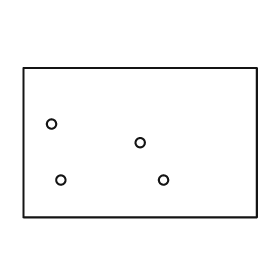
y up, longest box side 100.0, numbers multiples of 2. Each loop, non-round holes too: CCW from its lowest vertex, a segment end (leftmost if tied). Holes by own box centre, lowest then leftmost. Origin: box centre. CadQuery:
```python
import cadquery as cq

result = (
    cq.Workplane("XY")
    .moveTo(-50.0, -32.0)
    .lineTo(50.0, -32.0)
    .lineTo(50.0, 32.0)
    .lineTo(-50.0, 32.0)
    .close()
    .moveTo(-34.0, -16.0)
    .circle(2.0)
    .moveTo(10.0, -16.0)
    .circle(2.0)
    .moveTo(0.0, 0.0)
    .circle(2.0)
    .moveTo(-38.0, 8.0)
    .circle(2.0)
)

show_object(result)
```